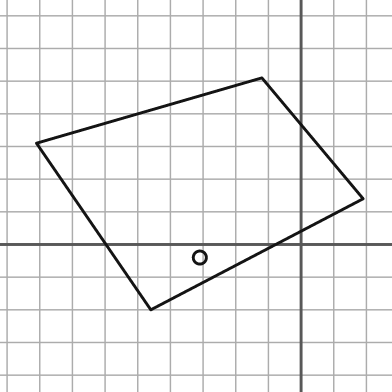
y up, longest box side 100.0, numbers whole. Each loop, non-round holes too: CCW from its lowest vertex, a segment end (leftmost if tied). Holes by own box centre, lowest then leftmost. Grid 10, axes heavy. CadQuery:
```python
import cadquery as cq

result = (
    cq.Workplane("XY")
    .moveTo(-46.0, -20.0)
    .lineTo(19.0, 14.0)
    .lineTo(-12.0, 51.0)
    .lineTo(-81.0, 31.0)
    .close()
    .moveTo(-31.0, -4.0)
    .circle(2.0)
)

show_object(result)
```